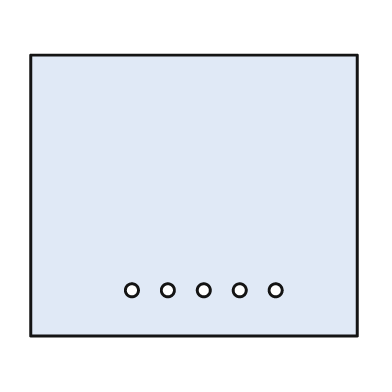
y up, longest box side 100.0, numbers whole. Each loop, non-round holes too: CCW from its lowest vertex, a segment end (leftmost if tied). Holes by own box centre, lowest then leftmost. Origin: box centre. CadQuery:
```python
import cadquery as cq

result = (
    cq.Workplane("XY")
    .moveTo(-50.0, -43.0)
    .lineTo(50.0, -43.0)
    .lineTo(50.0, 43.0)
    .lineTo(-50.0, 43.0)
    .close()
    .moveTo(-19.0, -29.0)
    .circle(2.0)
    .moveTo(-8.0, -29.0)
    .circle(2.0)
    .moveTo(3.0, -29.0)
    .circle(2.0)
    .moveTo(14.0, -29.0)
    .circle(2.0)
    .moveTo(25.0, -29.0)
    .circle(2.0)
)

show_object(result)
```